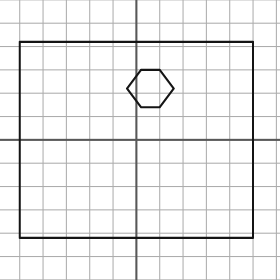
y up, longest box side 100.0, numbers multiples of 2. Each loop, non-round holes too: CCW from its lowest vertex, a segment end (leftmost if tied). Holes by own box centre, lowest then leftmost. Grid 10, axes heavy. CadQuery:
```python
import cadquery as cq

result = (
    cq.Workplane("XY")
    .moveTo(-50.0, -42.0)
    .lineTo(50.0, -42.0)
    .lineTo(50.0, 42.0)
    .lineTo(-50.0, 42.0)
    .close()
    .moveTo(2.0, 14.0)
    .lineTo(10.0, 14.0)
    .lineTo(16.0, 22.0)
    .lineTo(10.0, 30.0)
    .lineTo(2.0, 30.0)
    .lineTo(-4.0, 22.0)
    .close()
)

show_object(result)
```